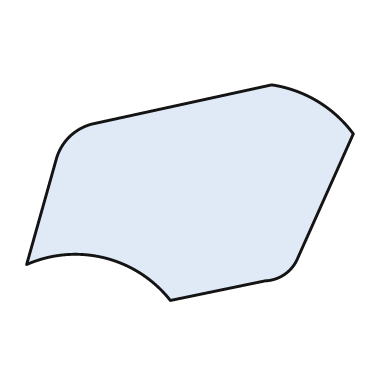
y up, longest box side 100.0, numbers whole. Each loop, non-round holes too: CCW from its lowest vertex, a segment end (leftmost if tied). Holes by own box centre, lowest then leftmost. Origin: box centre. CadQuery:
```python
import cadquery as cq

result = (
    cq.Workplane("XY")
    .moveTo(-6.0, -33.0)
    .lineTo(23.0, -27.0)
    .threePointArc((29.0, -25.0), (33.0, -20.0))
    .lineTo(50.0, 18.0)
    .threePointArc((39.0, 28.0), (25.0, 33.0))
    .lineTo(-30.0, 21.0)
    .threePointArc((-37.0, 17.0), (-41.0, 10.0))
    .lineTo(-50.0, -22.0)
    .threePointArc((-26.0, -20.0), (-6.0, -33.0))
    .close()
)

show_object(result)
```